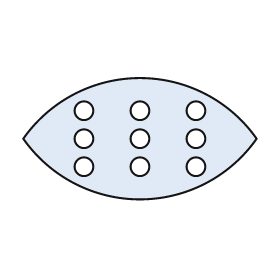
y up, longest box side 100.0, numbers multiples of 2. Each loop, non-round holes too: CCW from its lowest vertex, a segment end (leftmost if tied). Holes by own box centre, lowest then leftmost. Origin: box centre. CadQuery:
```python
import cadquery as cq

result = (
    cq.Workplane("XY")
    .moveTo(-50.0, 0.0)
    .threePointArc((0.0, -26.0), (50.0, 0.0))
    .threePointArc((0.0, 26.0), (-50.0, 0.0))
    .close()
    .moveTo(-24.0, -12.0)
    .circle(4.0)
    .moveTo(0.0, -12.0)
    .circle(4.0)
    .moveTo(24.0, -12.0)
    .circle(4.0)
    .moveTo(-24.0, 0.0)
    .circle(4.0)
    .moveTo(0.0, 0.0)
    .circle(4.0)
    .moveTo(24.0, 0.0)
    .circle(4.0)
    .moveTo(-24.0, 12.0)
    .circle(4.0)
    .moveTo(0.0, 12.0)
    .circle(4.0)
    .moveTo(24.0, 12.0)
    .circle(4.0)
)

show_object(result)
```